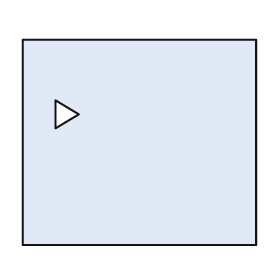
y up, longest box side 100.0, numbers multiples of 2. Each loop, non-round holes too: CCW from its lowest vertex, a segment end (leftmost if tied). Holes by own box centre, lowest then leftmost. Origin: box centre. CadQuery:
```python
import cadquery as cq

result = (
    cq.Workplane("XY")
    .moveTo(-50.0, -44.0)
    .lineTo(50.0, -44.0)
    .lineTo(50.0, 44.0)
    .lineTo(-50.0, 44.0)
    .close()
    .moveTo(-36.0, 6.0)
    .lineTo(-26.0, 12.0)
    .lineTo(-36.0, 18.0)
    .close()
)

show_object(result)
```